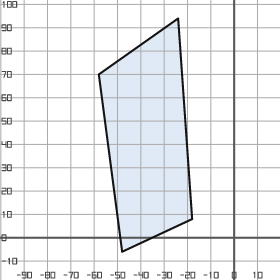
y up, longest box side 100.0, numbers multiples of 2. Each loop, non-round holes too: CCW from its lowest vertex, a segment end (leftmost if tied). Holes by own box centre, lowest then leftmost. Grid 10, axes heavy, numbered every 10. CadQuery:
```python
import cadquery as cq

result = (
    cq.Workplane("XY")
    .moveTo(-48.0, -6.0)
    .lineTo(-18.0, 8.0)
    .lineTo(-24.0, 94.0)
    .lineTo(-58.0, 70.0)
    .close()
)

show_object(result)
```